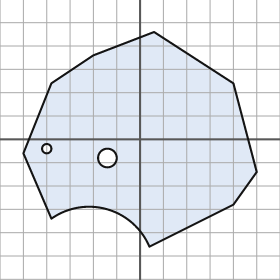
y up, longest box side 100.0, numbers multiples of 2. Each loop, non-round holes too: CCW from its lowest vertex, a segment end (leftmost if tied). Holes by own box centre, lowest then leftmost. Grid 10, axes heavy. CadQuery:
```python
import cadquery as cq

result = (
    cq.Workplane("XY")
    .moveTo(4.0, -46.0)
    .lineTo(40.0, -28.0)
    .lineTo(50.0, -14.0)
    .lineTo(40.0, 24.0)
    .lineTo(6.0, 46.0)
    .lineTo(-20.0, 36.0)
    .lineTo(-38.0, 24.0)
    .lineTo(-50.0, -6.0)
    .lineTo(-38.0, -34.0)
    .threePointArc((-14.0, -30.0), (4.0, -46.0))
    .close()
    .moveTo(-14.0, -8.0)
    .circle(4.0)
    .moveTo(-40.0, -4.0)
    .circle(2.0)
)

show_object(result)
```